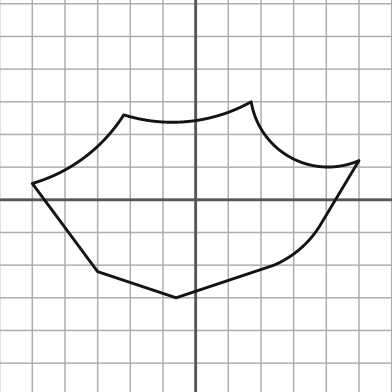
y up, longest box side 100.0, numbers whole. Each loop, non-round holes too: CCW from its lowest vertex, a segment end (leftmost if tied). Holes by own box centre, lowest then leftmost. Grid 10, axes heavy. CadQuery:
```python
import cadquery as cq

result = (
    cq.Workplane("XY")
    .moveTo(-6.0, -30.0)
    .lineTo(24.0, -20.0)
    .threePointArc((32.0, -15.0), (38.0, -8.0))
    .lineTo(50.0, 12.0)
    .threePointArc((29.0, 13.0), (17.0, 30.0))
    .threePointArc((-2.0, 24.0), (-22.0, 26.0))
    .threePointArc((-34.0, 13.0), (-50.0, 5.0))
    .lineTo(-30.0, -22.0)
    .close()
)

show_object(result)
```